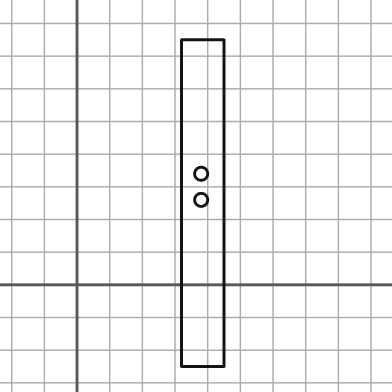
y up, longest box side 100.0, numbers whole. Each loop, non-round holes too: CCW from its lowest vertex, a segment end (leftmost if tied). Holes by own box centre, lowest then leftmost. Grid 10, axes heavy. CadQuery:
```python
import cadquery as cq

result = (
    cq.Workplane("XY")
    .moveTo(32.0, -25.0)
    .lineTo(45.0, -25.0)
    .lineTo(45.0, 75.0)
    .lineTo(32.0, 75.0)
    .close()
    .moveTo(38.0, 26.0)
    .circle(2.0)
    .moveTo(38.0, 34.0)
    .circle(2.0)
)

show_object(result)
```